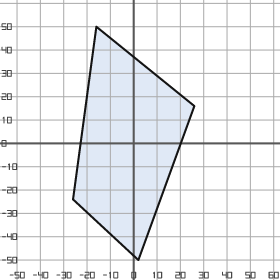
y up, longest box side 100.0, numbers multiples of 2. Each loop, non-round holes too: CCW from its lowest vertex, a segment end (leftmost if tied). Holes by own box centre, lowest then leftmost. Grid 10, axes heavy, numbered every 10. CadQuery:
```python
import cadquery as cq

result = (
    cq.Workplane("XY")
    .moveTo(2.0, -50.0)
    .lineTo(26.0, 16.0)
    .lineTo(-16.0, 50.0)
    .lineTo(-26.0, -24.0)
    .close()
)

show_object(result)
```